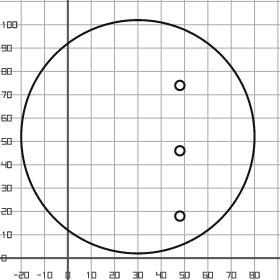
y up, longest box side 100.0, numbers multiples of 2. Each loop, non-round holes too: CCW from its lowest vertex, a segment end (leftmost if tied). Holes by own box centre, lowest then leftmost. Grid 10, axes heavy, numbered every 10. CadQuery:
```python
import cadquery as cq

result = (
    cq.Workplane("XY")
    .moveTo(30.0, 52.0)
    .circle(50.0)
    .moveTo(48.0, 18.0)
    .circle(2.0)
    .moveTo(48.0, 46.0)
    .circle(2.0)
    .moveTo(48.0, 74.0)
    .circle(2.0)
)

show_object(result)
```